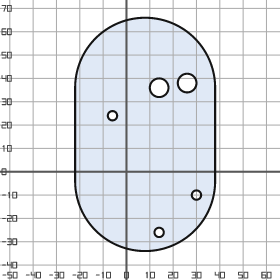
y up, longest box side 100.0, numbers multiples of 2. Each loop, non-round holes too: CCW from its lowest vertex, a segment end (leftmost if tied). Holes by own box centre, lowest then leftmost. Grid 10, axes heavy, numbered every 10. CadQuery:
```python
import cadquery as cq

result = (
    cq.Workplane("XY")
    .moveTo(-22.0, -4.0)
    .threePointArc((8.0, -34.0), (38.0, -4.0))
    .lineTo(38.0, 36.0)
    .threePointArc((8.0, 66.0), (-22.0, 36.0))
    .close()
    .moveTo(14.0, -26.0)
    .circle(2.0)
    .moveTo(30.0, -10.0)
    .circle(2.0)
    .moveTo(-6.0, 24.0)
    .circle(2.0)
    .moveTo(14.0, 36.0)
    .circle(4.0)
    .moveTo(26.0, 38.0)
    .circle(4.0)
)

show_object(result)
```